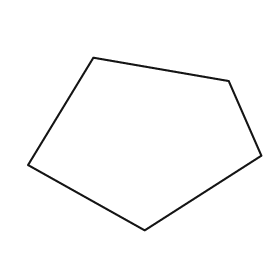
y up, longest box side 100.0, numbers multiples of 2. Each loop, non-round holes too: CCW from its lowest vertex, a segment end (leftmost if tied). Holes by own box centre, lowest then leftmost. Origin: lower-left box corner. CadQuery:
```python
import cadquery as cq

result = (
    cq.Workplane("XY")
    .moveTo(50.0, 0.0)
    .lineTo(100.0, 32.0)
    .lineTo(86.0, 64.0)
    .lineTo(28.0, 74.0)
    .lineTo(0.0, 28.0)
    .close()
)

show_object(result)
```